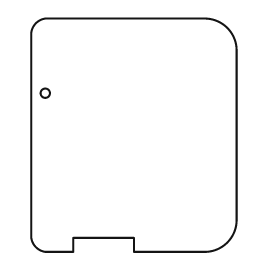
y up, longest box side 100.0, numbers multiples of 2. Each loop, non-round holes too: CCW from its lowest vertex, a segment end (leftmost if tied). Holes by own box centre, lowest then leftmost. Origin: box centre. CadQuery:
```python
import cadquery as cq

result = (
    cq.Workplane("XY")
    .moveTo(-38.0, -50.0)
    .lineTo(-26.0, -50.0)
    .lineTo(-26.0, -44.0)
    .lineTo(0.0, -44.0)
    .lineTo(0.0, -50.0)
    .lineTo(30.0, -50.0)
    .threePointArc((40.0, -46.0), (44.0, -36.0))
    .lineTo(44.0, 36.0)
    .threePointArc((40.0, 46.0), (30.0, 50.0))
    .lineTo(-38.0, 50.0)
    .threePointArc((-42.0, 48.0), (-44.0, 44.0))
    .lineTo(-44.0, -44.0)
    .threePointArc((-42.0, -48.0), (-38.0, -50.0))
    .close()
    .moveTo(-38.0, 18.0)
    .circle(2.0)
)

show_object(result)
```